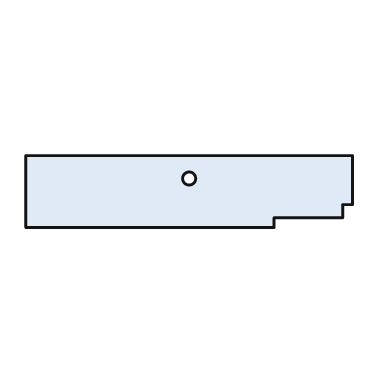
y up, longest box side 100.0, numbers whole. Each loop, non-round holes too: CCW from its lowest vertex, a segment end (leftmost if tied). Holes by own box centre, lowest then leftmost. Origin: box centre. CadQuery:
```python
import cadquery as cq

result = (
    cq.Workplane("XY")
    .moveTo(-50.0, -11.0)
    .lineTo(26.0, -11.0)
    .lineTo(26.0, -8.0)
    .lineTo(47.0, -8.0)
    .lineTo(47.0, -4.0)
    .lineTo(50.0, -4.0)
    .lineTo(50.0, 11.0)
    .lineTo(-50.0, 11.0)
    .close()
    .moveTo(0.0, 4.0)
    .circle(2.0)
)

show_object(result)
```